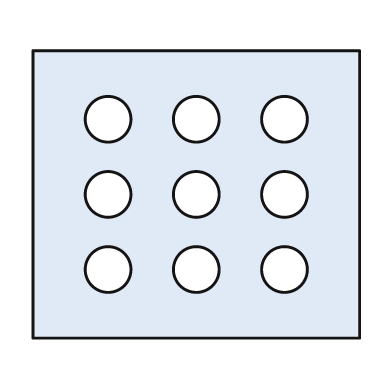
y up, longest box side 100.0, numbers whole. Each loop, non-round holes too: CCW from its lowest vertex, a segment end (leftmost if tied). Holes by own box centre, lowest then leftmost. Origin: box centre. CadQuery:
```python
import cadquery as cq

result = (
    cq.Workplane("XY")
    .moveTo(-50.0, -44.0)
    .lineTo(50.0, -44.0)
    .lineTo(50.0, 44.0)
    .lineTo(-50.0, 44.0)
    .close()
    .moveTo(-27.0, -23.0)
    .circle(7.0)
    .moveTo(0.0, -23.0)
    .circle(7.0)
    .moveTo(27.0, -23.0)
    .circle(7.0)
    .moveTo(-27.0, 0.0)
    .circle(7.0)
    .moveTo(0.0, 0.0)
    .circle(7.0)
    .moveTo(27.0, 0.0)
    .circle(7.0)
    .moveTo(-27.0, 23.0)
    .circle(7.0)
    .moveTo(0.0, 23.0)
    .circle(7.0)
    .moveTo(27.0, 23.0)
    .circle(7.0)
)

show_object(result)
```